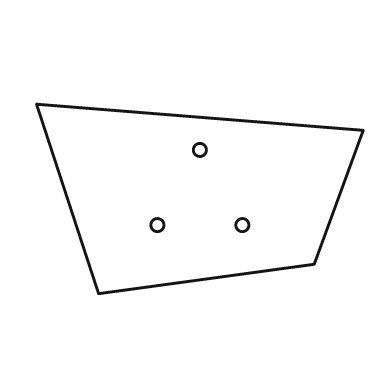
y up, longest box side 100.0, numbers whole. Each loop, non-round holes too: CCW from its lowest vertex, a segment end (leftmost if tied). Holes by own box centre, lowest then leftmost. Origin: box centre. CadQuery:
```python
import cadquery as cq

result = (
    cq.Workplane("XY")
    .moveTo(-31.0, -29.0)
    .lineTo(35.0, -20.0)
    .lineTo(50.0, 21.0)
    .lineTo(-50.0, 29.0)
    .close()
    .moveTo(-13.0, -8.0)
    .circle(2.0)
    .moveTo(13.0, -8.0)
    .circle(2.0)
    .moveTo(0.0, 15.0)
    .circle(2.0)
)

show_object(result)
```